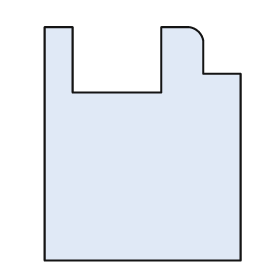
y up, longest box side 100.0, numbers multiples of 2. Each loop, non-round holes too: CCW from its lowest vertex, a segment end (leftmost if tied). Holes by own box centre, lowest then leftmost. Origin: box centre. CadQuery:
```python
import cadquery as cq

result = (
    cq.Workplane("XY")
    .moveTo(-42.0, -50.0)
    .lineTo(42.0, -50.0)
    .lineTo(42.0, 30.0)
    .lineTo(26.0, 30.0)
    .lineTo(26.0, 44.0)
    .threePointArc((24.0, 48.0), (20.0, 50.0))
    .lineTo(8.0, 50.0)
    .lineTo(8.0, 22.0)
    .lineTo(-30.0, 22.0)
    .lineTo(-30.0, 50.0)
    .lineTo(-42.0, 50.0)
    .close()
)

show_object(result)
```